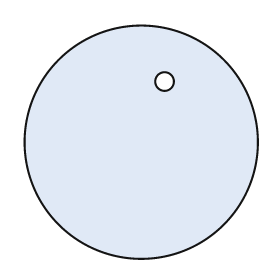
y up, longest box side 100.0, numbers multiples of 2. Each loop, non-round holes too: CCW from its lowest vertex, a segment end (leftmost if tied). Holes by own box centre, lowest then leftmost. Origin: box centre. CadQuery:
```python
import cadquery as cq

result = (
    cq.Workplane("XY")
    .moveTo(0.0, 0.0)
    .circle(50.0)
    .moveTo(10.0, 26.0)
    .circle(4.0)
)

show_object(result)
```